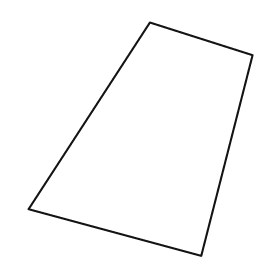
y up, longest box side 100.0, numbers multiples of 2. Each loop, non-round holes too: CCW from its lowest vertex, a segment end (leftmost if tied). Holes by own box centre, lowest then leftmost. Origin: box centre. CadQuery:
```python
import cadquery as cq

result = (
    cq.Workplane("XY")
    .moveTo(26.0, -50.0)
    .lineTo(48.0, 36.0)
    .lineTo(4.0, 50.0)
    .lineTo(-48.0, -30.0)
    .close()
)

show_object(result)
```